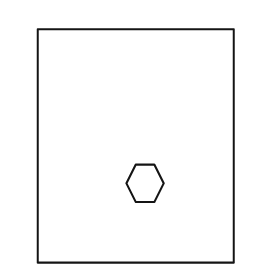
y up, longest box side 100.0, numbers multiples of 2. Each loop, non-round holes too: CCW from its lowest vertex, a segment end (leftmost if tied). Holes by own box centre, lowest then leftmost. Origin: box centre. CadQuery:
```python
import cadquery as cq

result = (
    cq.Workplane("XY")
    .moveTo(-42.0, -50.0)
    .lineTo(42.0, -50.0)
    .lineTo(42.0, 50.0)
    .lineTo(-42.0, 50.0)
    .close()
    .moveTo(0.0, -24.0)
    .lineTo(8.0, -24.0)
    .lineTo(12.0, -16.0)
    .lineTo(8.0, -8.0)
    .lineTo(0.0, -8.0)
    .lineTo(-4.0, -16.0)
    .close()
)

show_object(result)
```